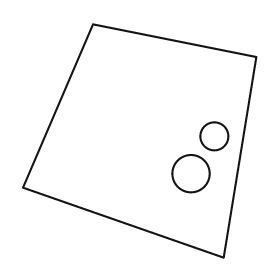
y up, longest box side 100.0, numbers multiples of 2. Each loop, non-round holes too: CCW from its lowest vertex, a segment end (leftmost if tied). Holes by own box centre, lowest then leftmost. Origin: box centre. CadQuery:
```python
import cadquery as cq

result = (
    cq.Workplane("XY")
    .moveTo(36.0, -50.0)
    .lineTo(50.0, 36.0)
    .lineTo(-20.0, 50.0)
    .lineTo(-50.0, -20.0)
    .close()
    .moveTo(22.0, -14.0)
    .circle(8.0)
    .moveTo(32.0, 2.0)
    .circle(6.0)
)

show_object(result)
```